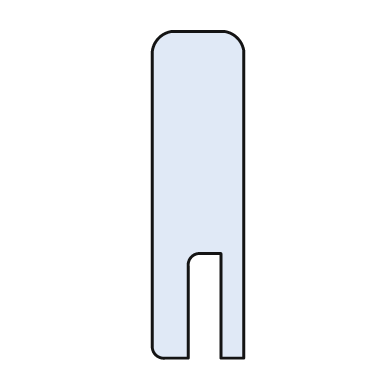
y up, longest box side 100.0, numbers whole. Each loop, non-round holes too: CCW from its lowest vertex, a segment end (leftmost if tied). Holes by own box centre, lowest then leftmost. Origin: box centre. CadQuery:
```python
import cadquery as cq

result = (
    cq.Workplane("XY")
    .moveTo(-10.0, -50.0)
    .lineTo(-3.0, -50.0)
    .lineTo(-3.0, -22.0)
    .threePointArc((-2.0, -19.0), (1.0, -18.0))
    .lineTo(7.0, -18.0)
    .lineTo(7.0, -50.0)
    .lineTo(14.0, -50.0)
    .lineTo(14.0, 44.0)
    .threePointArc((12.0, 48.0), (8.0, 50.0))
    .lineTo(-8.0, 50.0)
    .threePointArc((-12.0, 48.0), (-14.0, 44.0))
    .lineTo(-14.0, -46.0)
    .threePointArc((-13.0, -49.0), (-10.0, -50.0))
    .close()
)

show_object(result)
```